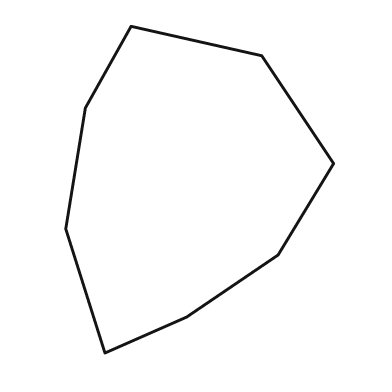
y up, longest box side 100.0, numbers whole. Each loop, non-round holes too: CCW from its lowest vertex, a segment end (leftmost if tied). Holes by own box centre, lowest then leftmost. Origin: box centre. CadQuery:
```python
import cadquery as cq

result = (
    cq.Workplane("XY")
    .moveTo(-29.0, -50.0)
    .lineTo(-4.0, -39.0)
    .lineTo(24.0, -20.0)
    .lineTo(41.0, 8.0)
    .lineTo(19.0, 41.0)
    .lineTo(-21.0, 50.0)
    .lineTo(-35.0, 25.0)
    .lineTo(-41.0, -12.0)
    .close()
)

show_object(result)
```